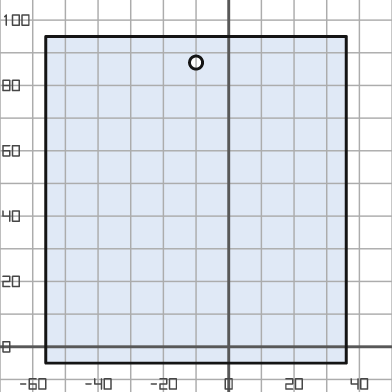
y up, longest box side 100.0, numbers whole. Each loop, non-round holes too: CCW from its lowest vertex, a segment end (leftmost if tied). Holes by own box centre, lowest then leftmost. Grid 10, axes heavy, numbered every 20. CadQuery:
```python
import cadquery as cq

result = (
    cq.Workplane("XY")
    .moveTo(-56.0, -5.0)
    .lineTo(36.0, -5.0)
    .lineTo(36.0, 95.0)
    .lineTo(-56.0, 95.0)
    .close()
    .moveTo(-10.0, 87.0)
    .circle(2.0)
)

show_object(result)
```